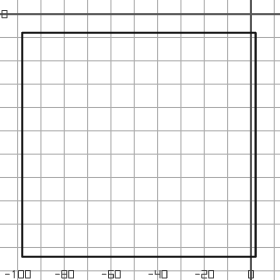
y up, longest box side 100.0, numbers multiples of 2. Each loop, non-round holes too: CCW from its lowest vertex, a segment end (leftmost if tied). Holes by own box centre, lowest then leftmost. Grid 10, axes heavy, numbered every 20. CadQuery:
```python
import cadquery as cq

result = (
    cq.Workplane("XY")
    .moveTo(-98.0, -104.0)
    .lineTo(2.0, -104.0)
    .lineTo(2.0, -8.0)
    .lineTo(-98.0, -8.0)
    .close()
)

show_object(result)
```